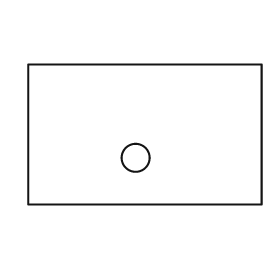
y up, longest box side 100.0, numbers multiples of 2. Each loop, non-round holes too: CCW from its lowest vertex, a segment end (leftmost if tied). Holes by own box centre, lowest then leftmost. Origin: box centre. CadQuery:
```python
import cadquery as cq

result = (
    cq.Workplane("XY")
    .moveTo(-50.0, -30.0)
    .lineTo(50.0, -30.0)
    .lineTo(50.0, 30.0)
    .lineTo(-50.0, 30.0)
    .close()
    .moveTo(-4.0, -10.0)
    .circle(6.0)
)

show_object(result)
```